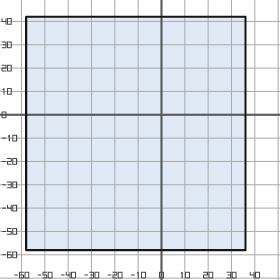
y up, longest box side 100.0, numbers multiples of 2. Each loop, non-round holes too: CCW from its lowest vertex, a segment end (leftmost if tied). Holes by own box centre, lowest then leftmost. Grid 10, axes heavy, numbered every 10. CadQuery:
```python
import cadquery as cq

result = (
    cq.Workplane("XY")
    .moveTo(-58.0, -58.0)
    .lineTo(36.0, -58.0)
    .lineTo(36.0, 42.0)
    .lineTo(-58.0, 42.0)
    .close()
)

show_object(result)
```